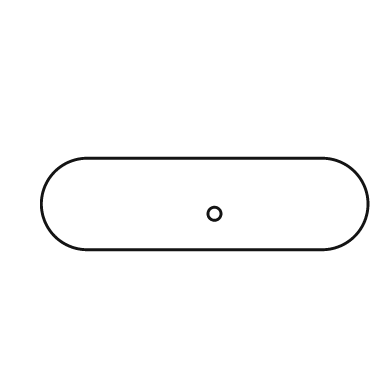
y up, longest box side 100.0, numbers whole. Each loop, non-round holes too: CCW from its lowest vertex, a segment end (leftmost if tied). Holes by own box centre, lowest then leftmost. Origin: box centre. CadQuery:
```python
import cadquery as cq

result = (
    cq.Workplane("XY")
    .moveTo(-36.0, -14.0)
    .lineTo(36.0, -14.0)
    .threePointArc((50.0, 0.0), (36.0, 14.0))
    .lineTo(-36.0, 14.0)
    .threePointArc((-50.0, 0.0), (-36.0, -14.0))
    .close()
    .moveTo(3.0, -3.0)
    .circle(2.0)
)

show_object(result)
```